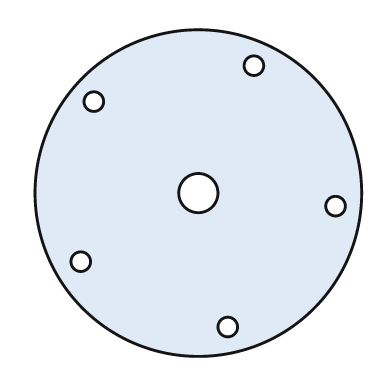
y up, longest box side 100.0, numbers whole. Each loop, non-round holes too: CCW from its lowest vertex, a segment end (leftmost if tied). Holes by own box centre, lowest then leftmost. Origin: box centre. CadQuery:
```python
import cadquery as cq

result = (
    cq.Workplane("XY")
    .moveTo(0.0, 0.0)
    .circle(50.0)
    .moveTo(9.0, -41.0)
    .circle(3.0)
    .moveTo(-36.0, -21.0)
    .circle(3.0)
    .moveTo(42.0, -4.0)
    .circle(3.0)
    .moveTo(0.0, 0.0)
    .circle(6.0)
    .moveTo(-32.0, 28.0)
    .circle(3.0)
    .moveTo(17.0, 39.0)
    .circle(3.0)
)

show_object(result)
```